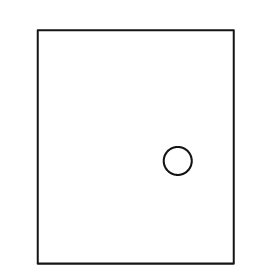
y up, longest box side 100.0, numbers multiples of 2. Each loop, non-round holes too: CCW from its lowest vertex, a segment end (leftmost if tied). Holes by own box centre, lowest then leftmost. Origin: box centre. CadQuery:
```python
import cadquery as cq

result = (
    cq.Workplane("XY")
    .moveTo(-42.0, -50.0)
    .lineTo(42.0, -50.0)
    .lineTo(42.0, 50.0)
    .lineTo(-42.0, 50.0)
    .close()
    .moveTo(18.0, -6.0)
    .circle(6.0)
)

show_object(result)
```